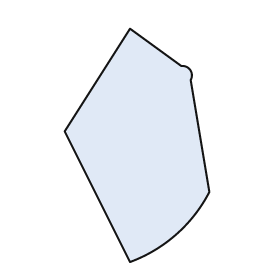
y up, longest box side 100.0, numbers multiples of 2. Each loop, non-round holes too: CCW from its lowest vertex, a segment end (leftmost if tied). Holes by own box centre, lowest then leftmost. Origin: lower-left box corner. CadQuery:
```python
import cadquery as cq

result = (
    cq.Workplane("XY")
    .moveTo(28.0, 0.0)
    .threePointArc((48.0, 12.0), (62.0, 30.0))
    .lineTo(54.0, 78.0)
    .threePointArc((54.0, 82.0), (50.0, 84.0))
    .lineTo(28.0, 100.0)
    .lineTo(0.0, 56.0)
    .close()
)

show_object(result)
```